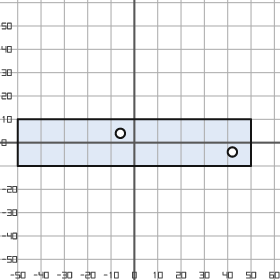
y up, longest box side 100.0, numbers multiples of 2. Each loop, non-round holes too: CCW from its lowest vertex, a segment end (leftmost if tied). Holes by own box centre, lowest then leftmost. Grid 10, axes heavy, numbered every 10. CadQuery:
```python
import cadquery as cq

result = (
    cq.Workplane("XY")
    .moveTo(-50.0, -10.0)
    .lineTo(50.0, -10.0)
    .lineTo(50.0, 10.0)
    .lineTo(-50.0, 10.0)
    .close()
    .moveTo(42.0, -4.0)
    .circle(2.0)
    .moveTo(-6.0, 4.0)
    .circle(2.0)
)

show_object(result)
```